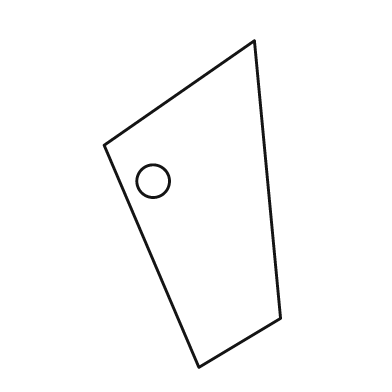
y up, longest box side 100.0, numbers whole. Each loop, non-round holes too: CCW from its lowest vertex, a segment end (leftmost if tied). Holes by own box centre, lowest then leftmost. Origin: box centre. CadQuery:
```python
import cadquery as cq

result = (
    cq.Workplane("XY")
    .moveTo(2.0, -50.0)
    .lineTo(27.0, -35.0)
    .lineTo(19.0, 50.0)
    .lineTo(-27.0, 18.0)
    .close()
    .moveTo(-12.0, 7.0)
    .circle(5.0)
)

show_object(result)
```